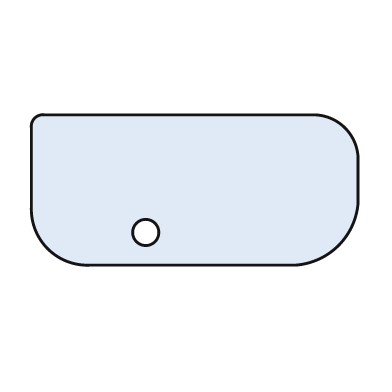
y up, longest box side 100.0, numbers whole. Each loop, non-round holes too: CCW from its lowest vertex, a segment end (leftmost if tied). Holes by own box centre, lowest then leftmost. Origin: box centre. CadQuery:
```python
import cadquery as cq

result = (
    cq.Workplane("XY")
    .moveTo(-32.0, -23.0)
    .lineTo(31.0, -23.0)
    .threePointArc((44.0, -17.0), (50.0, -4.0))
    .lineTo(50.0, 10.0)
    .threePointArc((46.0, 19.0), (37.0, 23.0))
    .lineTo(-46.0, 23.0)
    .threePointArc((-49.0, 22.0), (-50.0, 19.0))
    .lineTo(-50.0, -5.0)
    .threePointArc((-45.0, -18.0), (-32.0, -23.0))
    .close()
    .moveTo(-15.0, -13.0)
    .circle(4.0)
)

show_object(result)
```